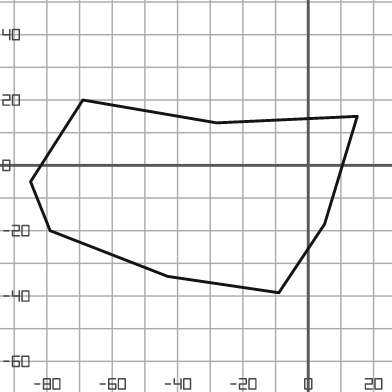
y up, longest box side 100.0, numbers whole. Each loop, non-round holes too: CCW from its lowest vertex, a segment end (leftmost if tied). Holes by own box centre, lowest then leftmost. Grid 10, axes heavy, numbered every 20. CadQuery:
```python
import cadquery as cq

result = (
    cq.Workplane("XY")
    .moveTo(-9.0, -39.0)
    .lineTo(5.0, -18.0)
    .lineTo(15.0, 15.0)
    .lineTo(-28.0, 13.0)
    .lineTo(-69.0, 20.0)
    .lineTo(-85.0, -5.0)
    .lineTo(-79.0, -20.0)
    .lineTo(-43.0, -34.0)
    .close()
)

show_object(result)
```